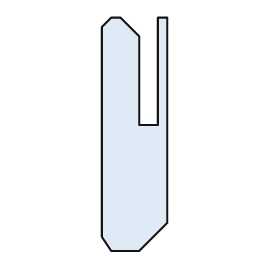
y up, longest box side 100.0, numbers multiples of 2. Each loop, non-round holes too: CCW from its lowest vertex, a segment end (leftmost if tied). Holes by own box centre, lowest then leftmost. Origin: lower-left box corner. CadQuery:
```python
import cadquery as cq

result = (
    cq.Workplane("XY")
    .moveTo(4.0, 0.0)
    .lineTo(16.0, 0.0)
    .lineTo(28.0, 12.0)
    .lineTo(28.0, 100.0)
    .lineTo(24.0, 100.0)
    .lineTo(24.0, 54.0)
    .lineTo(16.0, 54.0)
    .lineTo(16.0, 92.0)
    .lineTo(8.0, 100.0)
    .lineTo(4.0, 100.0)
    .lineTo(0.0, 96.0)
    .lineTo(0.0, 6.0)
    .close()
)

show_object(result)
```